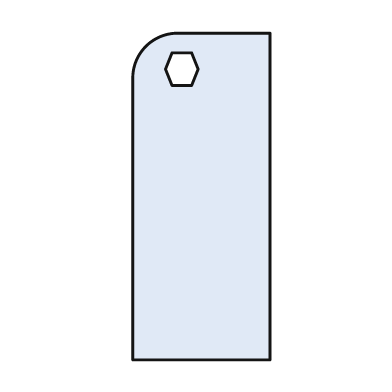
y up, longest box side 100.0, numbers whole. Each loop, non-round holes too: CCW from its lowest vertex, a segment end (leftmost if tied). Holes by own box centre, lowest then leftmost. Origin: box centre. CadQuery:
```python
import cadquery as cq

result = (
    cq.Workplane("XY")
    .moveTo(-21.0, -50.0)
    .lineTo(21.0, -50.0)
    .lineTo(21.0, 50.0)
    .lineTo(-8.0, 50.0)
    .threePointArc((-17.0, 46.0), (-21.0, 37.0))
    .close()
    .moveTo(-9.0, 34.0)
    .lineTo(-3.0, 34.0)
    .lineTo(-1.0, 39.0)
    .lineTo(-3.0, 44.0)
    .lineTo(-9.0, 44.0)
    .lineTo(-11.0, 39.0)
    .close()
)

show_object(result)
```